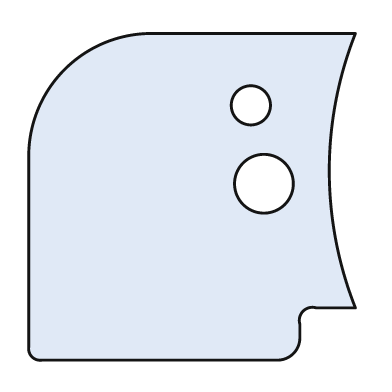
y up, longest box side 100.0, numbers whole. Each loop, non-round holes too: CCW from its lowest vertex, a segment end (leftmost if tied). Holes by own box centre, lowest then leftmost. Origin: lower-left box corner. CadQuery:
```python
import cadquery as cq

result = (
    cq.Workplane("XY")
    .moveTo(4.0, 0.0)
    .lineTo(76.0, 0.0)
    .threePointArc((81.0, 2.0), (83.0, 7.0))
    .lineTo(83.0, 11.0)
    .threePointArc((84.0, 15.0), (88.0, 16.0))
    .lineTo(100.0, 16.0)
    .threePointArc((92.0, 58.0), (100.0, 100.0))
    .lineTo(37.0, 100.0)
    .threePointArc((11.0, 89.0), (0.0, 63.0))
    .lineTo(0.0, 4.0)
    .threePointArc((1.0, 1.0), (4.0, 0.0))
    .close()
    .moveTo(72.0, 54.0)
    .circle(9.0)
    .moveTo(68.0, 78.0)
    .circle(6.0)
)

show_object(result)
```